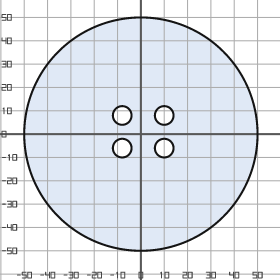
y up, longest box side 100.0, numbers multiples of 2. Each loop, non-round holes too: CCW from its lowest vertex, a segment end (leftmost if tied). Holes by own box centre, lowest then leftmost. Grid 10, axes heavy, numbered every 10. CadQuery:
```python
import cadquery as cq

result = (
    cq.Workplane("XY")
    .moveTo(0.0, 0.0)
    .circle(50.0)
    .moveTo(-8.0, -6.0)
    .circle(4.0)
    .moveTo(10.0, -6.0)
    .circle(4.0)
    .moveTo(-8.0, 8.0)
    .circle(4.0)
    .moveTo(10.0, 8.0)
    .circle(4.0)
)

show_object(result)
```